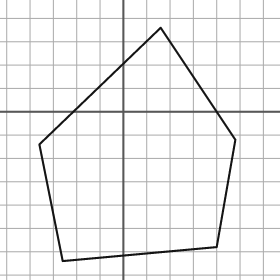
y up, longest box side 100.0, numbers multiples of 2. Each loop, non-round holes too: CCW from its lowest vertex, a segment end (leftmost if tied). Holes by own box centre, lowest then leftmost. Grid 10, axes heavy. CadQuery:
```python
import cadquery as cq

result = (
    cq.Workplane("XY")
    .moveTo(-26.0, -64.0)
    .lineTo(40.0, -58.0)
    .lineTo(48.0, -12.0)
    .lineTo(16.0, 36.0)
    .lineTo(-36.0, -14.0)
    .close()
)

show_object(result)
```